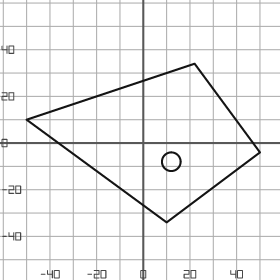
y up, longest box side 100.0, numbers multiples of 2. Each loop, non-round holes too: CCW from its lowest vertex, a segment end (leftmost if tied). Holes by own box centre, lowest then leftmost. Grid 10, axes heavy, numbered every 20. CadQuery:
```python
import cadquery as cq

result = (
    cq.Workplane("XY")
    .moveTo(10.0, -34.0)
    .lineTo(50.0, -4.0)
    .lineTo(22.0, 34.0)
    .lineTo(-50.0, 10.0)
    .close()
    .moveTo(12.0, -8.0)
    .circle(4.0)
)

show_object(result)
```